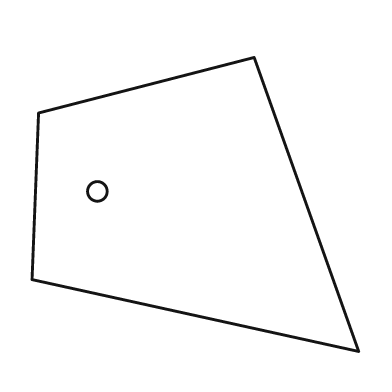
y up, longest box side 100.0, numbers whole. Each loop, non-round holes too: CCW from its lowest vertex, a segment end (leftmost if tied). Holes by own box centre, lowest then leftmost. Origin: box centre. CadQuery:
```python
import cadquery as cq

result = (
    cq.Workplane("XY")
    .moveTo(50.0, -45.0)
    .lineTo(18.0, 45.0)
    .lineTo(-48.0, 28.0)
    .lineTo(-50.0, -23.0)
    .close()
    .moveTo(-30.0, 4.0)
    .circle(3.0)
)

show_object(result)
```